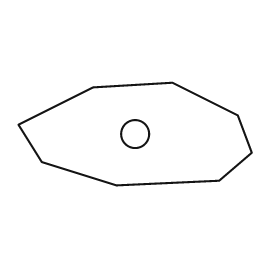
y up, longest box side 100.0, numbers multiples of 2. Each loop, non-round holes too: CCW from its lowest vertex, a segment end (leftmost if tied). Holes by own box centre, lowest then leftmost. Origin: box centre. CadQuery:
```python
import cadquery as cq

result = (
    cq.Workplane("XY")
    .moveTo(-8.0, -22.0)
    .lineTo(36.0, -20.0)
    .lineTo(50.0, -8.0)
    .lineTo(44.0, 8.0)
    .lineTo(16.0, 22.0)
    .lineTo(-18.0, 20.0)
    .lineTo(-50.0, 4.0)
    .lineTo(-40.0, -12.0)
    .close()
    .moveTo(0.0, 0.0)
    .circle(6.0)
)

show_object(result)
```